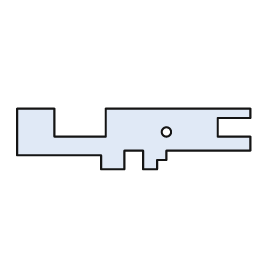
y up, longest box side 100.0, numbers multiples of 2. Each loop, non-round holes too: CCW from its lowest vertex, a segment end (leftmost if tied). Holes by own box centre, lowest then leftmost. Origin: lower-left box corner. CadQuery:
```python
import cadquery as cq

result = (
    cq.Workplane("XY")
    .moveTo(36.0, 0.0)
    .lineTo(46.0, 0.0)
    .lineTo(46.0, 8.0)
    .lineTo(54.0, 8.0)
    .lineTo(54.0, 0.0)
    .lineTo(60.0, 0.0)
    .lineTo(60.0, 4.0)
    .lineTo(64.0, 4.0)
    .lineTo(64.0, 8.0)
    .lineTo(100.0, 8.0)
    .lineTo(100.0, 14.0)
    .lineTo(86.0, 14.0)
    .lineTo(86.0, 22.0)
    .lineTo(100.0, 22.0)
    .lineTo(100.0, 26.0)
    .lineTo(38.0, 26.0)
    .lineTo(38.0, 14.0)
    .lineTo(16.0, 14.0)
    .lineTo(16.0, 26.0)
    .lineTo(0.0, 26.0)
    .lineTo(0.0, 6.0)
    .lineTo(36.0, 6.0)
    .close()
    .moveTo(64.0, 16.0)
    .circle(2.0)
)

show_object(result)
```